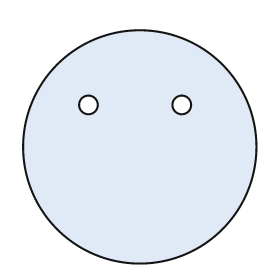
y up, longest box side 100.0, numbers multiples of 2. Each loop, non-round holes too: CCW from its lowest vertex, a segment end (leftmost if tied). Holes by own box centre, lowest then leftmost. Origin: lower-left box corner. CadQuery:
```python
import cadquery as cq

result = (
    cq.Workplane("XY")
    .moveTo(50.0, 50.0)
    .circle(50.0)
    .moveTo(28.0, 68.0)
    .circle(4.0)
    .moveTo(68.0, 68.0)
    .circle(4.0)
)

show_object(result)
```